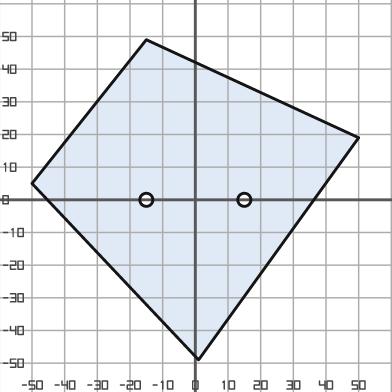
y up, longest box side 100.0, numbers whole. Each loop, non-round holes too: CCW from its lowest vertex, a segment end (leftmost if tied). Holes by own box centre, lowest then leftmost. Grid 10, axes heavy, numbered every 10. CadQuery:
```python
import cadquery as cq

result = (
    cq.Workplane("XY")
    .moveTo(1.0, -49.0)
    .lineTo(50.0, 19.0)
    .lineTo(-15.0, 49.0)
    .lineTo(-50.0, 5.0)
    .close()
    .moveTo(-15.0, 0.0)
    .circle(2.0)
    .moveTo(15.0, 0.0)
    .circle(2.0)
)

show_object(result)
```